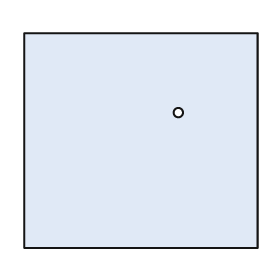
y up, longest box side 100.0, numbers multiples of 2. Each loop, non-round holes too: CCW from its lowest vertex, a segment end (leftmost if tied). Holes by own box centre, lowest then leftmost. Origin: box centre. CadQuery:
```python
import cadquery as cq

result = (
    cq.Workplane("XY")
    .moveTo(-50.0, -46.0)
    .lineTo(50.0, -46.0)
    .lineTo(50.0, 46.0)
    .lineTo(-50.0, 46.0)
    .close()
    .moveTo(16.0, 12.0)
    .circle(2.0)
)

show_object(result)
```